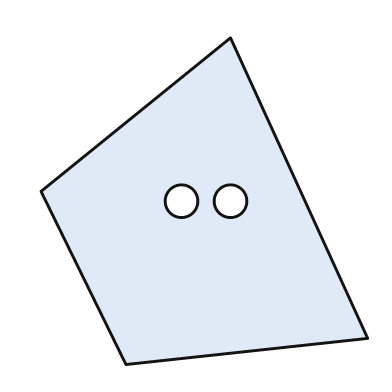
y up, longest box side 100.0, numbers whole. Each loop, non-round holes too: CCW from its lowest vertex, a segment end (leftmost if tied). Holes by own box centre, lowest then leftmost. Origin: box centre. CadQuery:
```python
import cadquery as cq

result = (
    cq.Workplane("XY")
    .moveTo(-24.0, -50.0)
    .lineTo(50.0, -42.0)
    .lineTo(8.0, 50.0)
    .lineTo(-50.0, 3.0)
    .close()
    .moveTo(-7.0, 0.0)
    .circle(5.0)
    .moveTo(8.0, 0.0)
    .circle(5.0)
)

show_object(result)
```